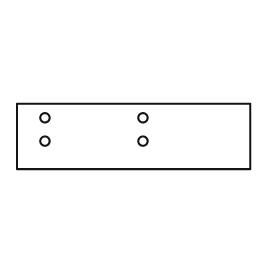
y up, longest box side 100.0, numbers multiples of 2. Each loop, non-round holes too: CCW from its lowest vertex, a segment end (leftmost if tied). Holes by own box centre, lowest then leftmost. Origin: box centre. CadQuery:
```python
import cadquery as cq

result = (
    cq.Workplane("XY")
    .moveTo(-50.0, -14.0)
    .lineTo(50.0, -14.0)
    .lineTo(50.0, 14.0)
    .lineTo(-50.0, 14.0)
    .close()
    .moveTo(-38.0, -2.0)
    .circle(2.0)
    .moveTo(4.0, -2.0)
    .circle(2.0)
    .moveTo(-38.0, 8.0)
    .circle(2.0)
    .moveTo(4.0, 8.0)
    .circle(2.0)
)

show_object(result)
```